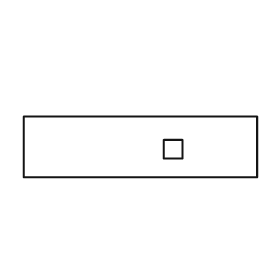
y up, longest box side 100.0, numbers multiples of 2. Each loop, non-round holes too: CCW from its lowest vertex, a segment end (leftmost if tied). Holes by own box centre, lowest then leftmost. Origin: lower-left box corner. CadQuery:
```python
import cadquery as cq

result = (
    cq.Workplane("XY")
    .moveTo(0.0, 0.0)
    .lineTo(100.0, 0.0)
    .lineTo(100.0, 26.0)
    .lineTo(0.0, 26.0)
    .close()
    .moveTo(60.0, 8.0)
    .lineTo(68.0, 8.0)
    .lineTo(68.0, 16.0)
    .lineTo(60.0, 16.0)
    .close()
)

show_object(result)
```